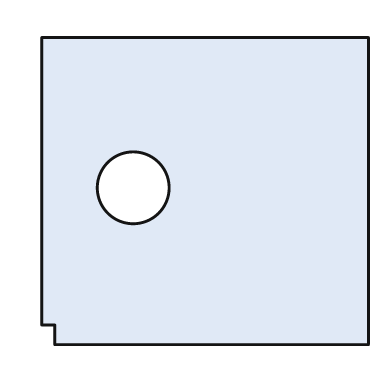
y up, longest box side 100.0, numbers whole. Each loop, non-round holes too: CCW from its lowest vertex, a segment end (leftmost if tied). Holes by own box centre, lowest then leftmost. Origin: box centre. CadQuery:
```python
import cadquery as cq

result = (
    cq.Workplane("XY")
    .moveTo(-46.0, -47.0)
    .lineTo(50.0, -47.0)
    .lineTo(50.0, 47.0)
    .lineTo(-50.0, 47.0)
    .lineTo(-50.0, -41.0)
    .lineTo(-46.0, -41.0)
    .close()
    .moveTo(-22.0, 1.0)
    .circle(11.0)
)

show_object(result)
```